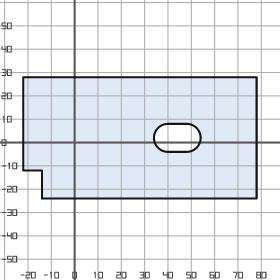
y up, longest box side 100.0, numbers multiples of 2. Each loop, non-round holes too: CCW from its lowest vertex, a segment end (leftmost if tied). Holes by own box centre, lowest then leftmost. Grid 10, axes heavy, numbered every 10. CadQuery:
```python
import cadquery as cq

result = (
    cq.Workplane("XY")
    .moveTo(-14.0, -24.0)
    .lineTo(78.0, -24.0)
    .lineTo(78.0, 28.0)
    .lineTo(-22.0, 28.0)
    .lineTo(-22.0, -12.0)
    .lineTo(-14.0, -12.0)
    .close()
    .moveTo(40.0, -4.0)
    .lineTo(48.0, -4.0)
    .threePointArc((54.0, 2.0), (48.0, 8.0))
    .lineTo(40.0, 8.0)
    .threePointArc((34.0, 2.0), (40.0, -4.0))
    .close()
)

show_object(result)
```